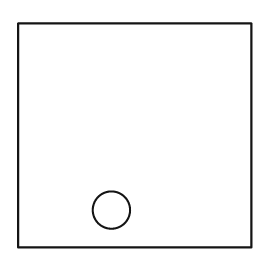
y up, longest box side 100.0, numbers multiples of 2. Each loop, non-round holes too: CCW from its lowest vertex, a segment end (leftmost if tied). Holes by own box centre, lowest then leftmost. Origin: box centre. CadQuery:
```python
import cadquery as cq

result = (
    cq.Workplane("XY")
    .moveTo(-50.0, -48.0)
    .lineTo(50.0, -48.0)
    .lineTo(50.0, 48.0)
    .lineTo(-50.0, 48.0)
    .close()
    .moveTo(-10.0, -32.0)
    .circle(8.0)
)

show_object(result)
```